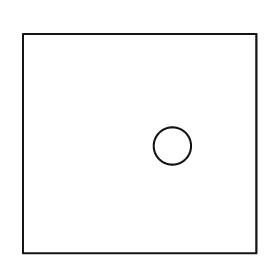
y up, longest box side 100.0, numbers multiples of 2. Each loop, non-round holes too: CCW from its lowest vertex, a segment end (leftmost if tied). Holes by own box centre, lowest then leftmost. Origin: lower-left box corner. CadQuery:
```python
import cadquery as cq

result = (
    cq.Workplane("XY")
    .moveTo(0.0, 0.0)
    .lineTo(100.0, 0.0)
    .lineTo(100.0, 94.0)
    .lineTo(0.0, 94.0)
    .close()
    .moveTo(64.0, 46.0)
    .circle(8.0)
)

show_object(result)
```